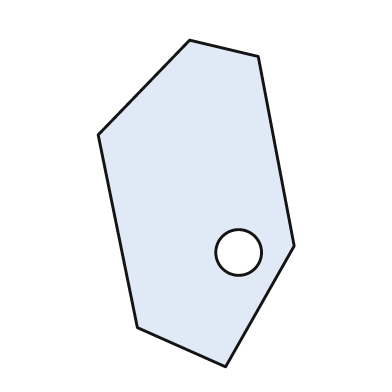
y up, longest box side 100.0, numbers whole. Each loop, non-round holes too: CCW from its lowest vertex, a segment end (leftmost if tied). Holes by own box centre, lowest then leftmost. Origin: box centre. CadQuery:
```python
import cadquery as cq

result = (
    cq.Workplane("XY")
    .moveTo(9.0, -50.0)
    .lineTo(30.0, -13.0)
    .lineTo(19.0, 45.0)
    .lineTo(-2.0, 50.0)
    .lineTo(-30.0, 21.0)
    .lineTo(-18.0, -38.0)
    .close()
    .moveTo(13.0, -15.0)
    .circle(7.0)
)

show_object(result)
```